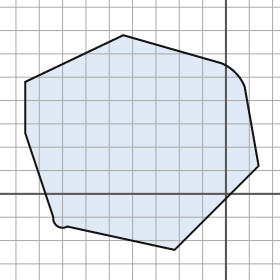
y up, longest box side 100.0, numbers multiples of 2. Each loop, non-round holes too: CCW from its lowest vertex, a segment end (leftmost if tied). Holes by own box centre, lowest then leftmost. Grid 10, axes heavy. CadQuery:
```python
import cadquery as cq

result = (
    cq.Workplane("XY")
    .moveTo(-22.0, -24.0)
    .lineTo(14.0, 12.0)
    .lineTo(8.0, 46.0)
    .threePointArc((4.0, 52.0), (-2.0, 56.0))
    .lineTo(-44.0, 68.0)
    .lineTo(-86.0, 48.0)
    .lineTo(-86.0, 26.0)
    .lineTo(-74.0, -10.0)
    .threePointArc((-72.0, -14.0), (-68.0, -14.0))
    .close()
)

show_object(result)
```